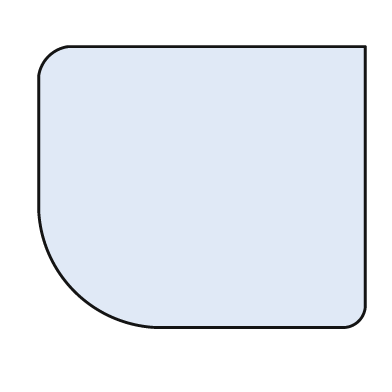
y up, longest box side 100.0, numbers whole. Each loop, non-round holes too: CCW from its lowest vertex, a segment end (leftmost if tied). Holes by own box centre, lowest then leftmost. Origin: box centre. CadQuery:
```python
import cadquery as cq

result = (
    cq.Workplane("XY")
    .moveTo(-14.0, -43.0)
    .lineTo(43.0, -43.0)
    .threePointArc((48.0, -41.0), (50.0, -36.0))
    .lineTo(50.0, 43.0)
    .lineTo(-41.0, 43.0)
    .threePointArc((-47.0, 40.0), (-50.0, 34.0))
    .lineTo(-50.0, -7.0)
    .threePointArc((-39.0, -32.0), (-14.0, -43.0))
    .close()
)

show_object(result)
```